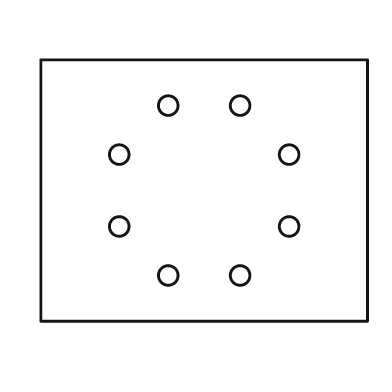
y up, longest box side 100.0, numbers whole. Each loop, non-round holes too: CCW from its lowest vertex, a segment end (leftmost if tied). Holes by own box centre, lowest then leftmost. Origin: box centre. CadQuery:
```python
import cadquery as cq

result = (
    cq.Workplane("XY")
    .moveTo(-50.0, -40.0)
    .lineTo(50.0, -40.0)
    .lineTo(50.0, 40.0)
    .lineTo(-50.0, 40.0)
    .close()
    .moveTo(-11.0, -26.0)
    .circle(3.0)
    .moveTo(11.0, -26.0)
    .circle(3.0)
    .moveTo(-26.0, -11.0)
    .circle(3.0)
    .moveTo(26.0, -11.0)
    .circle(3.0)
    .moveTo(-26.0, 11.0)
    .circle(3.0)
    .moveTo(26.0, 11.0)
    .circle(3.0)
    .moveTo(-11.0, 26.0)
    .circle(3.0)
    .moveTo(11.0, 26.0)
    .circle(3.0)
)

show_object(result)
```